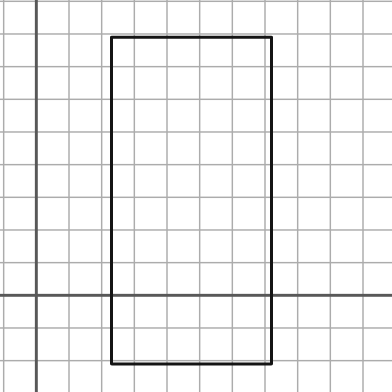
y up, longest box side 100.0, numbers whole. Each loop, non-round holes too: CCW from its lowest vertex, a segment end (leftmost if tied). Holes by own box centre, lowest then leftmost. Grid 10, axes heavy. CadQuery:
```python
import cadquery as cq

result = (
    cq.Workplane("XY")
    .moveTo(23.0, -21.0)
    .lineTo(72.0, -21.0)
    .lineTo(72.0, 79.0)
    .lineTo(23.0, 79.0)
    .close()
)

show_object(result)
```